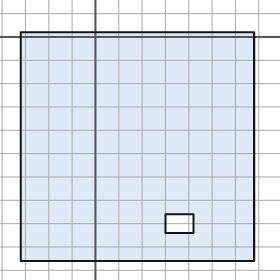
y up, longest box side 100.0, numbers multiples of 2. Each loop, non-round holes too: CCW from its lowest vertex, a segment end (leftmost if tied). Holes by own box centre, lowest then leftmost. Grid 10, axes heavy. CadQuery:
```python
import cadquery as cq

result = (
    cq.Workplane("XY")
    .moveTo(-32.0, -96.0)
    .lineTo(68.0, -96.0)
    .lineTo(68.0, 2.0)
    .lineTo(-32.0, 2.0)
    .close()
    .moveTo(30.0, -84.0)
    .lineTo(42.0, -84.0)
    .lineTo(42.0, -76.0)
    .lineTo(30.0, -76.0)
    .close()
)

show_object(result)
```